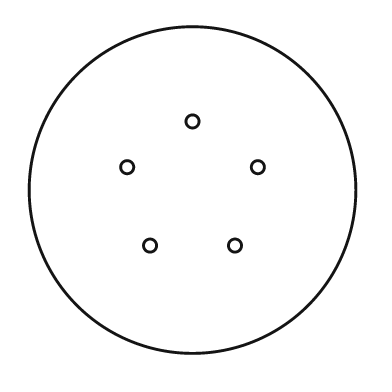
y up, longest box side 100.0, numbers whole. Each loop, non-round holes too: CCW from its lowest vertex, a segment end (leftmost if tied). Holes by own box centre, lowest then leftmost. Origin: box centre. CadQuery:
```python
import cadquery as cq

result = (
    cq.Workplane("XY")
    .moveTo(0.0, 0.0)
    .circle(50.0)
    .moveTo(-13.0, -17.0)
    .circle(2.0)
    .moveTo(13.0, -17.0)
    .circle(2.0)
    .moveTo(-20.0, 7.0)
    .circle(2.0)
    .moveTo(20.0, 7.0)
    .circle(2.0)
    .moveTo(0.0, 21.0)
    .circle(2.0)
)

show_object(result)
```